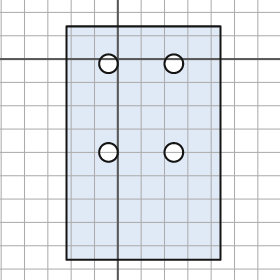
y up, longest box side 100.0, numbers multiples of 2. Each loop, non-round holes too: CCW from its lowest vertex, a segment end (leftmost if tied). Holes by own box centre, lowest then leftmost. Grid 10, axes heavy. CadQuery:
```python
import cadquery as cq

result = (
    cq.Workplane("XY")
    .moveTo(-22.0, -86.0)
    .lineTo(44.0, -86.0)
    .lineTo(44.0, 14.0)
    .lineTo(-22.0, 14.0)
    .close()
    .moveTo(-4.0, -40.0)
    .circle(4.0)
    .moveTo(24.0, -40.0)
    .circle(4.0)
    .moveTo(-4.0, -2.0)
    .circle(4.0)
    .moveTo(24.0, -2.0)
    .circle(4.0)
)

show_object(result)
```